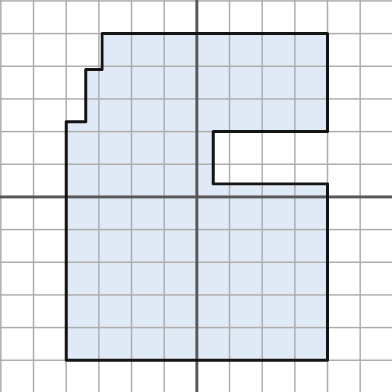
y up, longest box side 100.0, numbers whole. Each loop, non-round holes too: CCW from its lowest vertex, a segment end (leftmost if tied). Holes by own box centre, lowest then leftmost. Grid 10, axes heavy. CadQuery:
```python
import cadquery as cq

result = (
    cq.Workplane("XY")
    .moveTo(-40.0, -50.0)
    .lineTo(40.0, -50.0)
    .lineTo(40.0, 4.0)
    .lineTo(5.0, 4.0)
    .lineTo(5.0, 20.0)
    .lineTo(40.0, 20.0)
    .lineTo(40.0, 50.0)
    .lineTo(-29.0, 50.0)
    .lineTo(-29.0, 39.0)
    .lineTo(-34.0, 39.0)
    .lineTo(-34.0, 23.0)
    .lineTo(-40.0, 23.0)
    .close()
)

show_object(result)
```